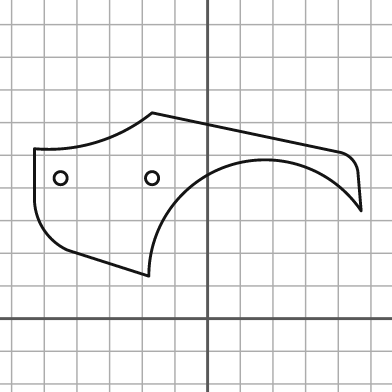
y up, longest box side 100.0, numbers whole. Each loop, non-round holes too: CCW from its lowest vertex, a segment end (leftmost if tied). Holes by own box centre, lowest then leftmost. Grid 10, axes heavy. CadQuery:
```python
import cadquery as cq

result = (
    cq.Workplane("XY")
    .moveTo(-18.0, 13.0)
    .threePointArc((7.0, 47.0), (47.0, 33.0))
    .lineTo(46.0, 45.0)
    .threePointArc((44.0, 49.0), (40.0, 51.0))
    .lineTo(-17.0, 63.0)
    .threePointArc((-34.0, 54.0), (-53.0, 52.0))
    .lineTo(-53.0, 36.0)
    .threePointArc((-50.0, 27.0), (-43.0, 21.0))
    .close()
    .moveTo(-45.0, 43.0)
    .circle(2.0)
    .moveTo(-17.0, 43.0)
    .circle(2.0)
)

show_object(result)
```